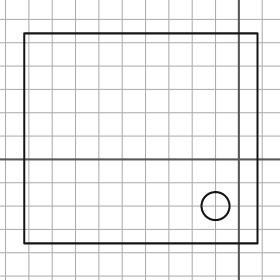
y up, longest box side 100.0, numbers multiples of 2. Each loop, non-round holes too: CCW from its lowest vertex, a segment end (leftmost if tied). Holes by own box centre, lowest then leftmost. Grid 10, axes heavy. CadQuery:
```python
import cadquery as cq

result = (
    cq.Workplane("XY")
    .moveTo(-92.0, -36.0)
    .lineTo(8.0, -36.0)
    .lineTo(8.0, 54.0)
    .lineTo(-92.0, 54.0)
    .close()
    .moveTo(-10.0, -20.0)
    .circle(6.0)
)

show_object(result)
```